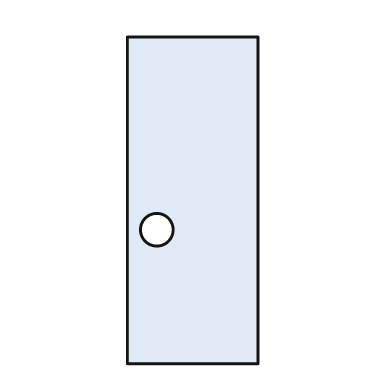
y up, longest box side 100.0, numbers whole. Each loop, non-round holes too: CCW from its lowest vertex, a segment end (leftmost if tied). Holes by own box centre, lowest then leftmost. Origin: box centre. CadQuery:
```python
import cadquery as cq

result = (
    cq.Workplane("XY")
    .moveTo(-20.0, -50.0)
    .lineTo(20.0, -50.0)
    .lineTo(20.0, 50.0)
    .lineTo(-20.0, 50.0)
    .close()
    .moveTo(-11.0, -9.0)
    .circle(5.0)
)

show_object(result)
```